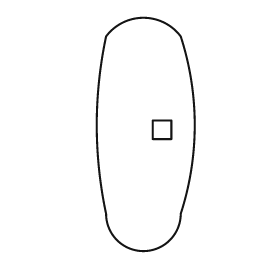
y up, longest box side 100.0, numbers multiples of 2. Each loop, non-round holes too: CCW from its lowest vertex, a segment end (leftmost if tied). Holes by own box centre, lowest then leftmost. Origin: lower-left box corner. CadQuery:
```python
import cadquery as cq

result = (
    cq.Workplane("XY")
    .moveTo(4.0, 16.0)
    .threePointArc((20.0, 0.0), (36.0, 16.0))
    .threePointArc((42.0, 54.0), (36.0, 92.0))
    .threePointArc((20.0, 100.0), (4.0, 92.0))
    .threePointArc((0.0, 54.0), (4.0, 16.0))
    .close()
    .moveTo(24.0, 48.0)
    .lineTo(32.0, 48.0)
    .lineTo(32.0, 56.0)
    .lineTo(24.0, 56.0)
    .close()
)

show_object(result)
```